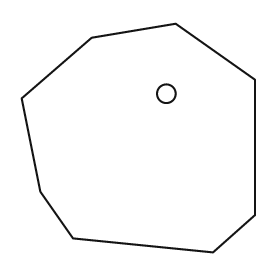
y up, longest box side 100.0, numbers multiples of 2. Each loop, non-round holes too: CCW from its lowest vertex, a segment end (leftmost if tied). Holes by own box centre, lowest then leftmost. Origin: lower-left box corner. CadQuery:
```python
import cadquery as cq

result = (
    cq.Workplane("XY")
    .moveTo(82.0, 0.0)
    .lineTo(100.0, 16.0)
    .lineTo(100.0, 74.0)
    .lineTo(66.0, 98.0)
    .lineTo(30.0, 92.0)
    .lineTo(0.0, 66.0)
    .lineTo(8.0, 26.0)
    .lineTo(22.0, 6.0)
    .close()
    .moveTo(62.0, 68.0)
    .circle(4.0)
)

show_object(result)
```